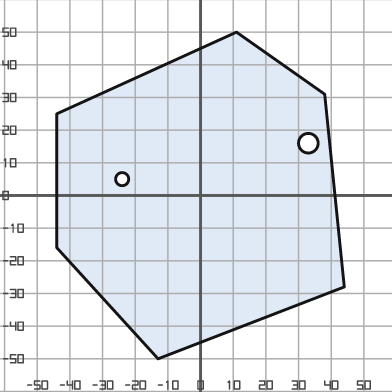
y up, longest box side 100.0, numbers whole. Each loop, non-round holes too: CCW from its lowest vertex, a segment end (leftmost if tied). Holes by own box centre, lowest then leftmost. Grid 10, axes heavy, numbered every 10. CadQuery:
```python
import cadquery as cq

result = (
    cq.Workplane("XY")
    .moveTo(-13.0, -50.0)
    .lineTo(44.0, -28.0)
    .lineTo(38.0, 31.0)
    .lineTo(11.0, 50.0)
    .lineTo(-44.0, 25.0)
    .lineTo(-44.0, -16.0)
    .close()
    .moveTo(-24.0, 5.0)
    .circle(2.0)
    .moveTo(33.0, 16.0)
    .circle(3.0)
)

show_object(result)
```